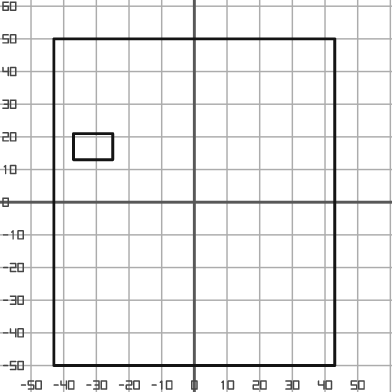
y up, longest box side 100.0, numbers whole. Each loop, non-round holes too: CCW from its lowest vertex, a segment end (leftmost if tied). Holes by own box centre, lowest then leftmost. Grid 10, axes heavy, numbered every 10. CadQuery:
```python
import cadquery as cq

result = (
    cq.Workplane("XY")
    .moveTo(-43.0, -50.0)
    .lineTo(43.0, -50.0)
    .lineTo(43.0, 50.0)
    .lineTo(-43.0, 50.0)
    .close()
    .moveTo(-37.0, 13.0)
    .lineTo(-25.0, 13.0)
    .lineTo(-25.0, 21.0)
    .lineTo(-37.0, 21.0)
    .close()
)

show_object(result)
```